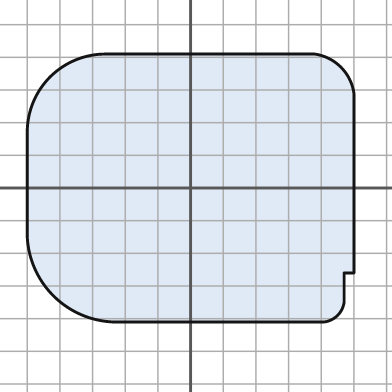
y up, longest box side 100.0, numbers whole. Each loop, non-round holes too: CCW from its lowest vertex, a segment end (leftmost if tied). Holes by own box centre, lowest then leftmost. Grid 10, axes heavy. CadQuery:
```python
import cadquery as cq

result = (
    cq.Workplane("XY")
    .moveTo(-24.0, -41.0)
    .lineTo(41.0, -41.0)
    .threePointArc((45.0, -39.0), (47.0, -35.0))
    .lineTo(47.0, -26.0)
    .lineTo(50.0, -26.0)
    .lineTo(50.0, 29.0)
    .threePointArc((46.0, 37.0), (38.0, 41.0))
    .lineTo(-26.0, 41.0)
    .threePointArc((-43.0, 34.0), (-50.0, 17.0))
    .lineTo(-50.0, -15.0)
    .threePointArc((-42.0, -33.0), (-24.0, -41.0))
    .close()
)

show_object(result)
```